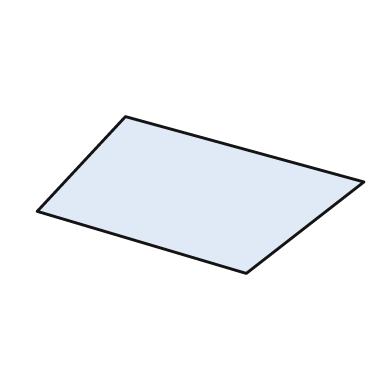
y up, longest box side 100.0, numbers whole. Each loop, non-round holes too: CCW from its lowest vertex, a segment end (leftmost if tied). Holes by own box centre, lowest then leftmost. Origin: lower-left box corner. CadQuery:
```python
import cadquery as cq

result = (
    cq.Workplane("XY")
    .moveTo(64.0, 0.0)
    .lineTo(100.0, 28.0)
    .lineTo(27.0, 48.0)
    .lineTo(0.0, 19.0)
    .close()
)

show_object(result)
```